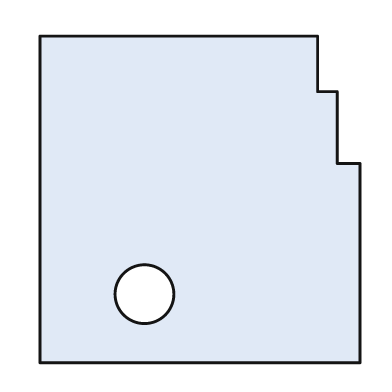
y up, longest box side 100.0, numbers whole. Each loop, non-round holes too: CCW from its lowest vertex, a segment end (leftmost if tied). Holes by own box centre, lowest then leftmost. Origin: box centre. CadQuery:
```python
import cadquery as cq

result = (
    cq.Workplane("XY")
    .moveTo(-49.0, -50.0)
    .lineTo(49.0, -50.0)
    .lineTo(49.0, 11.0)
    .lineTo(42.0, 11.0)
    .lineTo(42.0, 33.0)
    .lineTo(36.0, 33.0)
    .lineTo(36.0, 50.0)
    .lineTo(-49.0, 50.0)
    .close()
    .moveTo(-17.0, -29.0)
    .circle(9.0)
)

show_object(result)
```